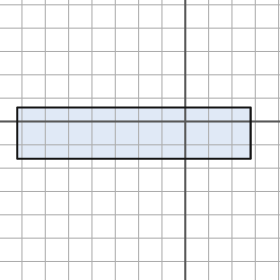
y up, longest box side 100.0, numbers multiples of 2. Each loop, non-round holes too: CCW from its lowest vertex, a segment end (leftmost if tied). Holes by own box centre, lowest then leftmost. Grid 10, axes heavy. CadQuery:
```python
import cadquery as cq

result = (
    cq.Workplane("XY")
    .moveTo(-72.0, -16.0)
    .lineTo(28.0, -16.0)
    .lineTo(28.0, 6.0)
    .lineTo(-72.0, 6.0)
    .close()
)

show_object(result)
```